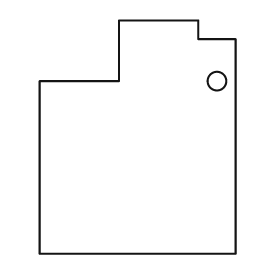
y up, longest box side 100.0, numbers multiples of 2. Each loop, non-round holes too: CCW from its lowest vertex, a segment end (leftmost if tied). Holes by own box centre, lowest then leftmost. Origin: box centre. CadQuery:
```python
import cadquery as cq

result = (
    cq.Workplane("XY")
    .moveTo(-42.0, -50.0)
    .lineTo(42.0, -50.0)
    .lineTo(42.0, 42.0)
    .lineTo(26.0, 42.0)
    .lineTo(26.0, 50.0)
    .lineTo(-8.0, 50.0)
    .lineTo(-8.0, 24.0)
    .lineTo(-42.0, 24.0)
    .close()
    .moveTo(34.0, 24.0)
    .circle(4.0)
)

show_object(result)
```